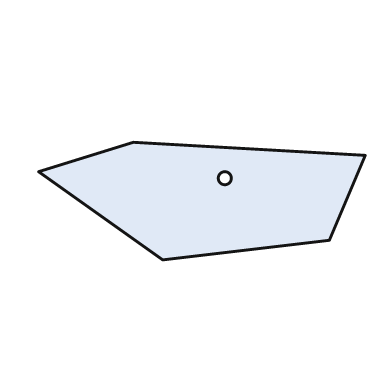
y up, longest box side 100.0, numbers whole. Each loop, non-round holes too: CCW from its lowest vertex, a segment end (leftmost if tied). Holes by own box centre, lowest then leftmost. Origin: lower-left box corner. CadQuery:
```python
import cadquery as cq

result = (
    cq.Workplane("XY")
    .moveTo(38.0, 0.0)
    .lineTo(89.0, 6.0)
    .lineTo(100.0, 32.0)
    .lineTo(29.0, 36.0)
    .lineTo(0.0, 27.0)
    .close()
    .moveTo(57.0, 25.0)
    .circle(2.0)
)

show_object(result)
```